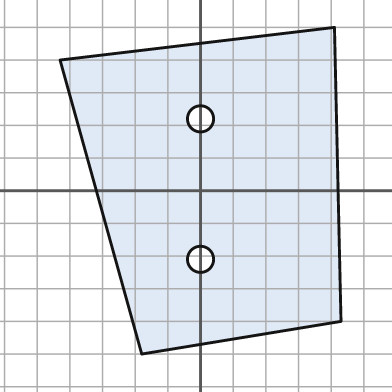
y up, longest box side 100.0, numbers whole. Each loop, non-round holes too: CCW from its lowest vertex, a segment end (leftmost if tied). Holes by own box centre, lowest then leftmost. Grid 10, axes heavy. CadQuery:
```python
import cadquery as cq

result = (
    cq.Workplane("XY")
    .moveTo(-18.0, -50.0)
    .lineTo(43.0, -40.0)
    .lineTo(41.0, 50.0)
    .lineTo(-43.0, 40.0)
    .close()
    .moveTo(0.0, -21.0)
    .circle(4.0)
    .moveTo(0.0, 22.0)
    .circle(4.0)
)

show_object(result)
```